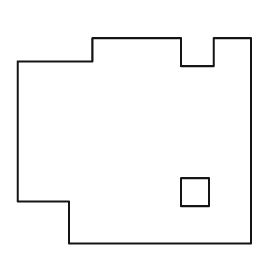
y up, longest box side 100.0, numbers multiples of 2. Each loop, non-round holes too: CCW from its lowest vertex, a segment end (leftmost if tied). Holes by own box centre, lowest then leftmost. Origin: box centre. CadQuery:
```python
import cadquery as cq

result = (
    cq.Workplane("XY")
    .moveTo(-28.0, -44.0)
    .lineTo(50.0, -44.0)
    .lineTo(50.0, 44.0)
    .lineTo(34.0, 44.0)
    .lineTo(34.0, 32.0)
    .lineTo(20.0, 32.0)
    .lineTo(20.0, 44.0)
    .lineTo(-18.0, 44.0)
    .lineTo(-18.0, 34.0)
    .lineTo(-50.0, 34.0)
    .lineTo(-50.0, -26.0)
    .lineTo(-28.0, -26.0)
    .close()
    .moveTo(20.0, -28.0)
    .lineTo(32.0, -28.0)
    .lineTo(32.0, -16.0)
    .lineTo(20.0, -16.0)
    .close()
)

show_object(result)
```